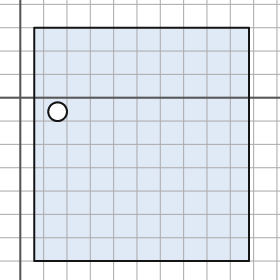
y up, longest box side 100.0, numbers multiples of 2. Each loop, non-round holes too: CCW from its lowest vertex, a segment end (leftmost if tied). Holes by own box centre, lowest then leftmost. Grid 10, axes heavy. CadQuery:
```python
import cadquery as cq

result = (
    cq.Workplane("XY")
    .moveTo(6.0, -70.0)
    .lineTo(98.0, -70.0)
    .lineTo(98.0, 30.0)
    .lineTo(6.0, 30.0)
    .close()
    .moveTo(16.0, -6.0)
    .circle(4.0)
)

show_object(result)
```